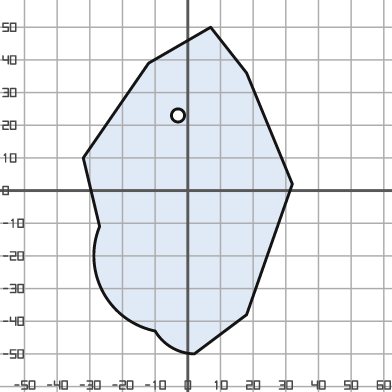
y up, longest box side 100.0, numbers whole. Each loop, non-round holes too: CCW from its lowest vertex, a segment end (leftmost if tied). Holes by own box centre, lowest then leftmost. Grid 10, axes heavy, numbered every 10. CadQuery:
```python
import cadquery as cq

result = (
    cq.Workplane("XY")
    .moveTo(2.0, -50.0)
    .lineTo(18.0, -38.0)
    .lineTo(32.0, 2.0)
    .lineTo(18.0, 36.0)
    .lineTo(7.0, 50.0)
    .lineTo(-12.0, 39.0)
    .lineTo(-32.0, 10.0)
    .lineTo(-27.0, -11.0)
    .threePointArc((-26.0, -31.0), (-10.0, -43.0))
    .threePointArc((-5.0, -48.0), (2.0, -50.0))
    .close()
    .moveTo(-3.0, 23.0)
    .circle(2.0)
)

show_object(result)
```